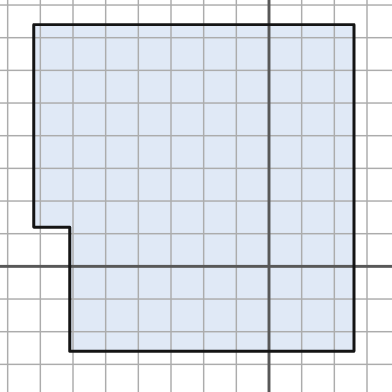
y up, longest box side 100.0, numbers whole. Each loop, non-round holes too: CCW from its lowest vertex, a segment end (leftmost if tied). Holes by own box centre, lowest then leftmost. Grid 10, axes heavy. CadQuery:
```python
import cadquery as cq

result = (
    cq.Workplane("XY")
    .moveTo(-61.0, -26.0)
    .lineTo(26.0, -26.0)
    .lineTo(26.0, 74.0)
    .lineTo(-72.0, 74.0)
    .lineTo(-72.0, 12.0)
    .lineTo(-61.0, 12.0)
    .close()
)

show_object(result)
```